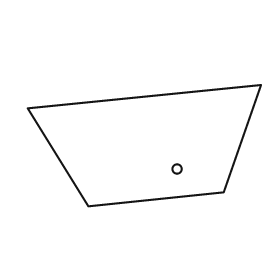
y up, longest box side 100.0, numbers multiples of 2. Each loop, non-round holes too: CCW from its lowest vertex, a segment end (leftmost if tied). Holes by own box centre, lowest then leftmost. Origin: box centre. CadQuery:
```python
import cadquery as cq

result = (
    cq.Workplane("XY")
    .moveTo(-24.0, -26.0)
    .lineTo(34.0, -20.0)
    .lineTo(50.0, 26.0)
    .lineTo(-50.0, 16.0)
    .close()
    .moveTo(14.0, -10.0)
    .circle(2.0)
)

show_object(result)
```